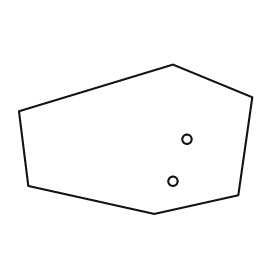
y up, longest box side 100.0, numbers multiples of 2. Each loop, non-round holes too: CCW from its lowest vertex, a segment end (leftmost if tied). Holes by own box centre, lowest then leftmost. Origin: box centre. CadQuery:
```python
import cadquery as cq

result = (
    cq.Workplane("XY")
    .moveTo(8.0, -32.0)
    .lineTo(44.0, -24.0)
    .lineTo(50.0, 18.0)
    .lineTo(16.0, 32.0)
    .lineTo(-50.0, 12.0)
    .lineTo(-46.0, -20.0)
    .close()
    .moveTo(16.0, -18.0)
    .circle(2.0)
    .moveTo(22.0, 0.0)
    .circle(2.0)
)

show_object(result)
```